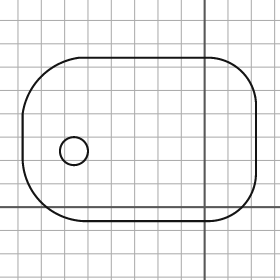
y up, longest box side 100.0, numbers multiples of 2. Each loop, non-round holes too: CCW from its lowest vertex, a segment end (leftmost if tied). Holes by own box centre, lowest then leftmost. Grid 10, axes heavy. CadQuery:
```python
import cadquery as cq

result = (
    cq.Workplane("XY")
    .moveTo(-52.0, -6.0)
    .lineTo(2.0, -6.0)
    .threePointArc((16.0, 0.0), (22.0, 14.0))
    .lineTo(22.0, 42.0)
    .threePointArc((16.0, 58.0), (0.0, 64.0))
    .lineTo(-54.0, 64.0)
    .threePointArc((-70.0, 56.0), (-78.0, 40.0))
    .lineTo(-78.0, 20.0)
    .threePointArc((-70.0, 2.0), (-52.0, -6.0))
    .close()
    .moveTo(-56.0, 24.0)
    .circle(6.0)
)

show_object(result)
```